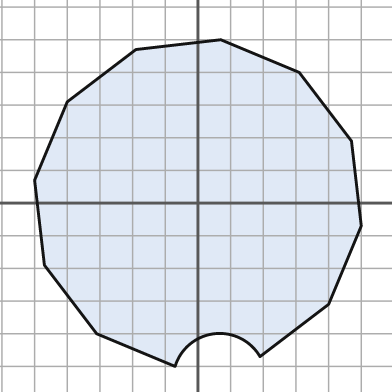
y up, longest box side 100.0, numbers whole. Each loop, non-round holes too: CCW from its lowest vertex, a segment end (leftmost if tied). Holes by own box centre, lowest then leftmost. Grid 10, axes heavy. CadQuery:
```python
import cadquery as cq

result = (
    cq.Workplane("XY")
    .moveTo(-7.0, -50.0)
    .threePointArc((5.0, -40.0), (19.0, -47.0))
    .lineTo(40.0, -31.0)
    .lineTo(50.0, -7.0)
    .lineTo(47.0, 19.0)
    .lineTo(31.0, 40.0)
    .lineTo(7.0, 50.0)
    .lineTo(-19.0, 47.0)
    .lineTo(-40.0, 31.0)
    .lineTo(-50.0, 7.0)
    .lineTo(-47.0, -19.0)
    .lineTo(-31.0, -40.0)
    .close()
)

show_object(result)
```